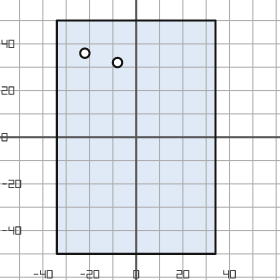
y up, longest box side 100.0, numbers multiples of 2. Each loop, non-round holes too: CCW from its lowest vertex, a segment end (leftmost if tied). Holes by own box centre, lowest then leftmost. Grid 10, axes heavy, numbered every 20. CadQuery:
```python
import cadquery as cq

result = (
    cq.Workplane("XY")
    .moveTo(-34.0, -50.0)
    .lineTo(34.0, -50.0)
    .lineTo(34.0, 50.0)
    .lineTo(-34.0, 50.0)
    .close()
    .moveTo(-8.0, 32.0)
    .circle(2.0)
    .moveTo(-22.0, 36.0)
    .circle(2.0)
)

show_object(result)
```